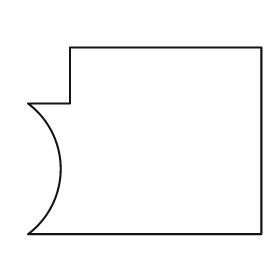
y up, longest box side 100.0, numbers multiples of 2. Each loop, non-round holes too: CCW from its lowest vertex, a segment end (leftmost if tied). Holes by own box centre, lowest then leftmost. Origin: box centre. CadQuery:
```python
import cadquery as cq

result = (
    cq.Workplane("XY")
    .moveTo(-50.0, -40.0)
    .lineTo(50.0, -40.0)
    .lineTo(50.0, 40.0)
    .lineTo(-32.0, 40.0)
    .lineTo(-32.0, 16.0)
    .lineTo(-50.0, 16.0)
    .threePointArc((-36.0, -12.0), (-50.0, -40.0))
    .close()
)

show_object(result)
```